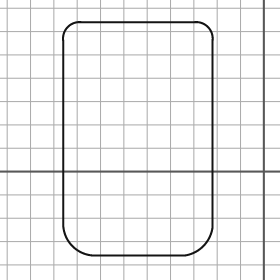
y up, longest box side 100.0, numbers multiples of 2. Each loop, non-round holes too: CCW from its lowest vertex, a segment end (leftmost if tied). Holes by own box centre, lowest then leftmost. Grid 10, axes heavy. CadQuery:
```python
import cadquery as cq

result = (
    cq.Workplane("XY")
    .moveTo(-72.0, -36.0)
    .lineTo(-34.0, -36.0)
    .threePointArc((-26.0, -32.0), (-22.0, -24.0))
    .lineTo(-22.0, 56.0)
    .threePointArc((-24.0, 62.0), (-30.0, 64.0))
    .lineTo(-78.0, 64.0)
    .threePointArc((-84.0, 62.0), (-86.0, 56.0))
    .lineTo(-86.0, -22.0)
    .threePointArc((-82.0, -32.0), (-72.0, -36.0))
    .close()
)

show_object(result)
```